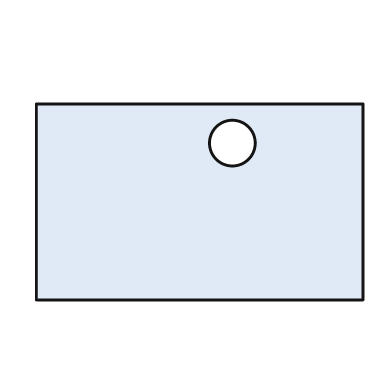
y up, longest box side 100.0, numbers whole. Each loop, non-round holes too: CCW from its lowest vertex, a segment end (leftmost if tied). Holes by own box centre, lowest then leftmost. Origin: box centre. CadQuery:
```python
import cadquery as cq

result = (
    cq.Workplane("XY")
    .moveTo(-50.0, -30.0)
    .lineTo(50.0, -30.0)
    .lineTo(50.0, 30.0)
    .lineTo(-50.0, 30.0)
    .close()
    .moveTo(10.0, 18.0)
    .circle(7.0)
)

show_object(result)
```